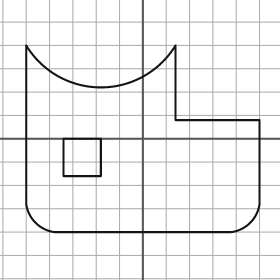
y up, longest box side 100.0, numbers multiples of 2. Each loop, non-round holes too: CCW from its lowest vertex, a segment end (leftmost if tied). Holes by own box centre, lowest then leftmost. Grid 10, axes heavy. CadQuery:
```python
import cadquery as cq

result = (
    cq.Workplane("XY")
    .moveTo(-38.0, -40.0)
    .lineTo(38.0, -40.0)
    .threePointArc((46.0, -36.0), (50.0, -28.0))
    .lineTo(50.0, 8.0)
    .lineTo(14.0, 8.0)
    .lineTo(14.0, 40.0)
    .threePointArc((-18.0, 22.0), (-50.0, 40.0))
    .lineTo(-50.0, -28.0)
    .threePointArc((-46.0, -36.0), (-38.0, -40.0))
    .close()
    .moveTo(-34.0, -16.0)
    .lineTo(-18.0, -16.0)
    .lineTo(-18.0, 0.0)
    .lineTo(-34.0, 0.0)
    .close()
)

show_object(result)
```